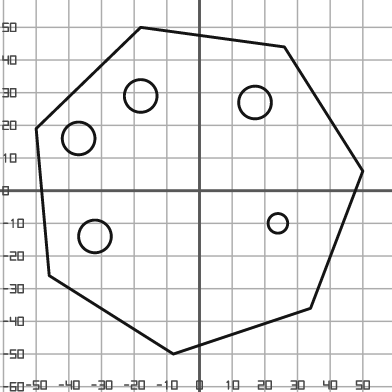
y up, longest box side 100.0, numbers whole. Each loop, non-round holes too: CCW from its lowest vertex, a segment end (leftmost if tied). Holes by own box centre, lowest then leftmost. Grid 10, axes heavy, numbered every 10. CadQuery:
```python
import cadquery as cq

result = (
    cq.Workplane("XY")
    .moveTo(-8.0, -50.0)
    .lineTo(34.0, -36.0)
    .lineTo(50.0, 6.0)
    .lineTo(26.0, 44.0)
    .lineTo(-18.0, 50.0)
    .lineTo(-50.0, 19.0)
    .lineTo(-46.0, -26.0)
    .close()
    .moveTo(-32.0, -14.0)
    .circle(5.0)
    .moveTo(24.0, -10.0)
    .circle(3.0)
    .moveTo(-37.0, 16.0)
    .circle(5.0)
    .moveTo(17.0, 27.0)
    .circle(5.0)
    .moveTo(-18.0, 29.0)
    .circle(5.0)
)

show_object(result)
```